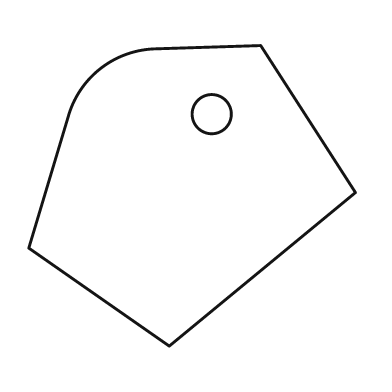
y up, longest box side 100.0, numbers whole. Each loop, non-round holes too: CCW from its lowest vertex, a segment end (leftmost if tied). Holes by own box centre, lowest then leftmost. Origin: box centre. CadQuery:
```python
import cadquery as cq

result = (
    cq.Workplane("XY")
    .moveTo(-7.0, -46.0)
    .lineTo(50.0, 1.0)
    .lineTo(21.0, 46.0)
    .lineTo(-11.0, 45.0)
    .threePointArc((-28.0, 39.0), (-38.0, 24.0))
    .lineTo(-50.0, -16.0)
    .close()
    .moveTo(6.0, 25.0)
    .circle(6.0)
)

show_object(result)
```